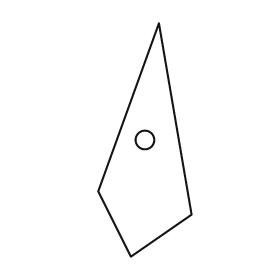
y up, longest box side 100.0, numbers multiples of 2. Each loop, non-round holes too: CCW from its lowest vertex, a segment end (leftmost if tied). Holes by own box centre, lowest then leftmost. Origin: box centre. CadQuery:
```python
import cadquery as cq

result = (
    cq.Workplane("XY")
    .moveTo(-6.0, -50.0)
    .lineTo(20.0, -32.0)
    .lineTo(6.0, 50.0)
    .lineTo(-20.0, -22.0)
    .close()
    .moveTo(0.0, 0.0)
    .circle(4.0)
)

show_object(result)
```